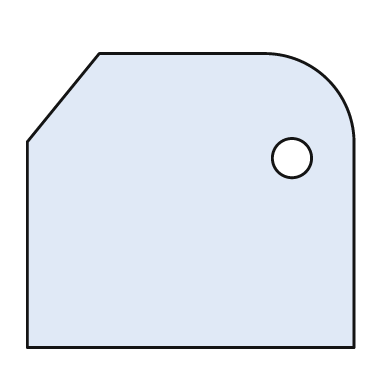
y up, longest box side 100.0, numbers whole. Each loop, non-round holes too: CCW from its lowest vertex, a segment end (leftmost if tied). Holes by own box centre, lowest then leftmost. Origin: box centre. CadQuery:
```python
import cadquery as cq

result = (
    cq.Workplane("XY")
    .moveTo(-50.0, -45.0)
    .lineTo(50.0, -45.0)
    .lineTo(50.0, 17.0)
    .threePointArc((42.0, 37.0), (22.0, 45.0))
    .lineTo(-28.0, 45.0)
    .lineTo(-50.0, 18.0)
    .close()
    .moveTo(31.0, 13.0)
    .circle(6.0)
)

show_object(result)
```